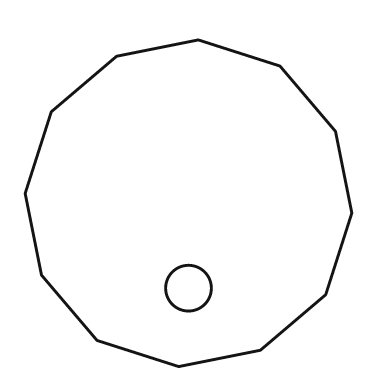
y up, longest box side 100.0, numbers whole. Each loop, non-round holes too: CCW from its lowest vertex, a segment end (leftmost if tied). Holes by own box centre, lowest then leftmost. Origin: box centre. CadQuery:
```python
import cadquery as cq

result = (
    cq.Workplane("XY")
    .moveTo(-3.0, -50.0)
    .lineTo(22.0, -45.0)
    .lineTo(42.0, -28.0)
    .lineTo(50.0, -3.0)
    .lineTo(45.0, 22.0)
    .lineTo(28.0, 42.0)
    .lineTo(3.0, 50.0)
    .lineTo(-22.0, 45.0)
    .lineTo(-42.0, 28.0)
    .lineTo(-50.0, 3.0)
    .lineTo(-45.0, -22.0)
    .lineTo(-28.0, -42.0)
    .close()
    .moveTo(0.0, -26.0)
    .circle(7.0)
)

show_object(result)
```